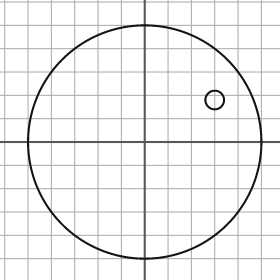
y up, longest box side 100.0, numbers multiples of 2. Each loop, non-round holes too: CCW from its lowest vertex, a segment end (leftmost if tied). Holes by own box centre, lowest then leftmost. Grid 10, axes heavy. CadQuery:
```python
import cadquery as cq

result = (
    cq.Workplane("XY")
    .moveTo(0.0, 0.0)
    .circle(50.0)
    .moveTo(30.0, 18.0)
    .circle(4.0)
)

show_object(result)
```